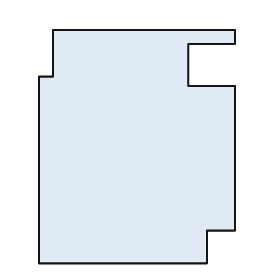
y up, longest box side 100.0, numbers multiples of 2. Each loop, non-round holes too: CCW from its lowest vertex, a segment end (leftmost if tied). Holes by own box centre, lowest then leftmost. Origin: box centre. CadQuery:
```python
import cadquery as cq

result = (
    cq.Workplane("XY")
    .moveTo(-42.0, -50.0)
    .lineTo(30.0, -50.0)
    .lineTo(30.0, -36.0)
    .lineTo(42.0, -36.0)
    .lineTo(42.0, 26.0)
    .lineTo(22.0, 26.0)
    .lineTo(22.0, 44.0)
    .lineTo(42.0, 44.0)
    .lineTo(42.0, 50.0)
    .lineTo(-36.0, 50.0)
    .lineTo(-36.0, 30.0)
    .lineTo(-42.0, 30.0)
    .close()
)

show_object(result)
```